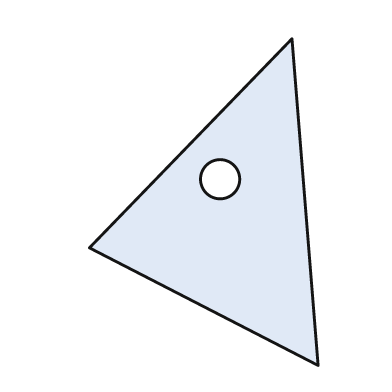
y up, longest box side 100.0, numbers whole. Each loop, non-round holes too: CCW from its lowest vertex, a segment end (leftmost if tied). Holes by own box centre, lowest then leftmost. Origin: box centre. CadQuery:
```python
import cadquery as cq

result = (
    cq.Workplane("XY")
    .moveTo(35.0, -50.0)
    .lineTo(27.0, 50.0)
    .lineTo(-35.0, -14.0)
    .close()
    .moveTo(5.0, 7.0)
    .circle(6.0)
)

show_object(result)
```